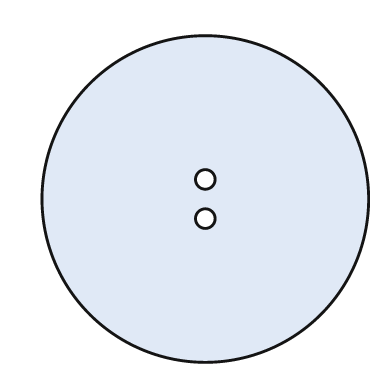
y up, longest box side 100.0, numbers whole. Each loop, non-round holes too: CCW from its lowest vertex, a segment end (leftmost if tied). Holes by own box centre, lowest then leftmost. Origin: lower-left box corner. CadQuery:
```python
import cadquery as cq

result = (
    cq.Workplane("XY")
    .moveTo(50.0, 50.0)
    .circle(50.0)
    .moveTo(50.0, 44.0)
    .circle(3.0)
    .moveTo(50.0, 56.0)
    .circle(3.0)
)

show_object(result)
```